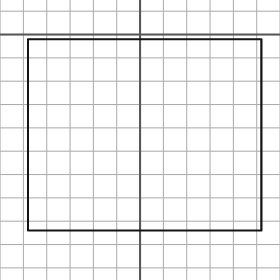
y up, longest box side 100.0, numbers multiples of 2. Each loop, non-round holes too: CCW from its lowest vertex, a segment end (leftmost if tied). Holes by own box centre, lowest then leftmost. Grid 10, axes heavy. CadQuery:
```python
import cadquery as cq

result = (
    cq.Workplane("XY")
    .moveTo(-48.0, -84.0)
    .lineTo(52.0, -84.0)
    .lineTo(52.0, -2.0)
    .lineTo(-48.0, -2.0)
    .close()
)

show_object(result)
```